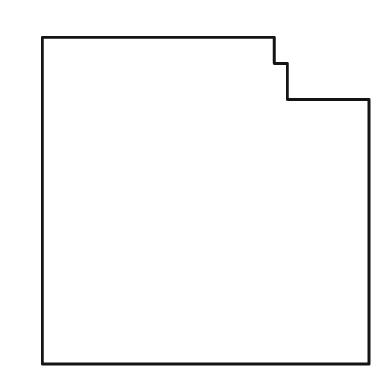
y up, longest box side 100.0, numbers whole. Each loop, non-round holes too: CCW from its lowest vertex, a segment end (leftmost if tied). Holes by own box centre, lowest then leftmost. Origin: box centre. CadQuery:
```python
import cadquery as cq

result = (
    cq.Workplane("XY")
    .moveTo(-50.0, -50.0)
    .lineTo(50.0, -50.0)
    .lineTo(50.0, 31.0)
    .lineTo(25.0, 31.0)
    .lineTo(25.0, 42.0)
    .lineTo(21.0, 42.0)
    .lineTo(21.0, 50.0)
    .lineTo(-50.0, 50.0)
    .close()
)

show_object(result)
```